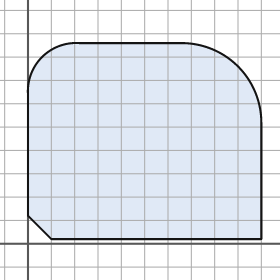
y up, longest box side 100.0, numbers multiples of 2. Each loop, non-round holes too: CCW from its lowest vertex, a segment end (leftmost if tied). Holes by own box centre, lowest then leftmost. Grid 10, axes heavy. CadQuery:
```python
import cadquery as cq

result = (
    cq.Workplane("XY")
    .moveTo(10.0, 2.0)
    .lineTo(100.0, 2.0)
    .lineTo(100.0, 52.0)
    .threePointArc((90.0, 76.0), (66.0, 86.0))
    .lineTo(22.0, 86.0)
    .threePointArc((6.0, 80.0), (0.0, 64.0))
    .lineTo(0.0, 12.0)
    .close()
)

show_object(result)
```